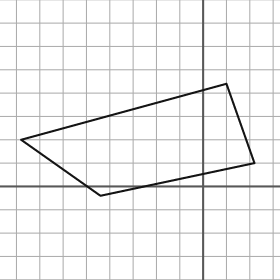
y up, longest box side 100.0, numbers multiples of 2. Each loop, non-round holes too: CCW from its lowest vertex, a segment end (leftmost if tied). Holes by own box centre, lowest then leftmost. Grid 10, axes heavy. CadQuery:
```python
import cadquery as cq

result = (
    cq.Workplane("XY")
    .moveTo(-44.0, -4.0)
    .lineTo(22.0, 10.0)
    .lineTo(10.0, 44.0)
    .lineTo(-78.0, 20.0)
    .close()
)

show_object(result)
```